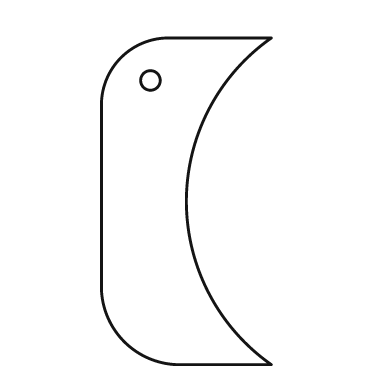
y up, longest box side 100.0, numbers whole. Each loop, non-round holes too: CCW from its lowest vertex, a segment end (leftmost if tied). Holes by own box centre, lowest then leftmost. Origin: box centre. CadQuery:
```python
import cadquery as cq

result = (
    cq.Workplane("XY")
    .moveTo(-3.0, -50.0)
    .lineTo(26.0, -50.0)
    .threePointArc((0.0, 0.0), (26.0, 50.0))
    .lineTo(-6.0, 50.0)
    .threePointArc((-20.0, 44.0), (-26.0, 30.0))
    .lineTo(-26.0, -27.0)
    .threePointArc((-19.0, -43.0), (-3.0, -50.0))
    .close()
    .moveTo(-11.0, 37.0)
    .circle(3.0)
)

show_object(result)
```